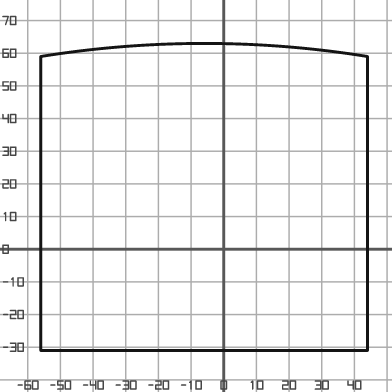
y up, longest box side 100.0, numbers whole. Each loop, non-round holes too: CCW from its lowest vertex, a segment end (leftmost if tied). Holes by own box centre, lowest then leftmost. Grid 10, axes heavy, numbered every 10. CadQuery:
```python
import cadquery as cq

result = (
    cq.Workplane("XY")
    .moveTo(-56.0, -31.0)
    .lineTo(44.0, -31.0)
    .lineTo(44.0, 59.0)
    .threePointArc((-6.0, 63.0), (-56.0, 59.0))
    .close()
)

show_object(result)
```